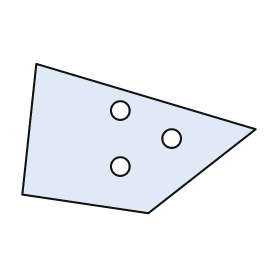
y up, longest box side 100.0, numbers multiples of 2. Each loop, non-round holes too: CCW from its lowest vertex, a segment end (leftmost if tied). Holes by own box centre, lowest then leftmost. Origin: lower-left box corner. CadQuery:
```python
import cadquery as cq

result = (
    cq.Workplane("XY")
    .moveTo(54.0, 0.0)
    .lineTo(100.0, 36.0)
    .lineTo(6.0, 64.0)
    .lineTo(0.0, 8.0)
    .close()
    .moveTo(42.0, 20.0)
    .circle(4.0)
    .moveTo(64.0, 32.0)
    .circle(4.0)
    .moveTo(42.0, 44.0)
    .circle(4.0)
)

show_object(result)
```